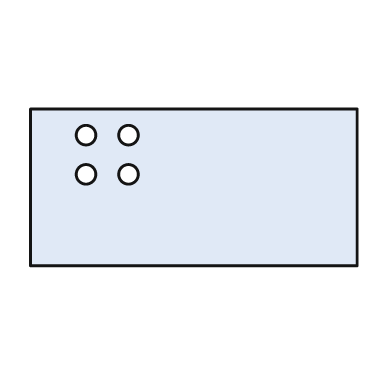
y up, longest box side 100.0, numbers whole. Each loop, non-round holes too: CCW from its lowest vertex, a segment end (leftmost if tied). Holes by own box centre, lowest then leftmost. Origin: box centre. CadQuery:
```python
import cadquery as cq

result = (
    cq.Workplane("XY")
    .moveTo(-50.0, -24.0)
    .lineTo(50.0, -24.0)
    .lineTo(50.0, 24.0)
    .lineTo(-50.0, 24.0)
    .close()
    .moveTo(-33.0, 4.0)
    .circle(3.0)
    .moveTo(-20.0, 4.0)
    .circle(3.0)
    .moveTo(-33.0, 16.0)
    .circle(3.0)
    .moveTo(-20.0, 16.0)
    .circle(3.0)
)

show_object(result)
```